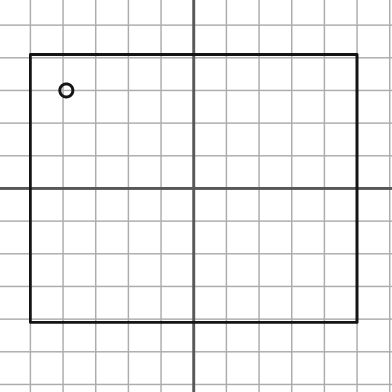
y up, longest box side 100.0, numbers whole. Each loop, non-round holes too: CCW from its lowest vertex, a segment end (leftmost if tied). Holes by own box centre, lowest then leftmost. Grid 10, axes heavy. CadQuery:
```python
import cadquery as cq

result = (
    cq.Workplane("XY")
    .moveTo(-50.0, -41.0)
    .lineTo(50.0, -41.0)
    .lineTo(50.0, 41.0)
    .lineTo(-50.0, 41.0)
    .close()
    .moveTo(-39.0, 30.0)
    .circle(2.0)
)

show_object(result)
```